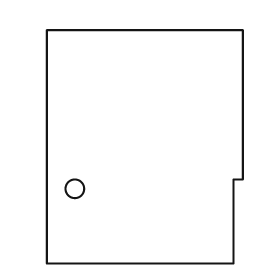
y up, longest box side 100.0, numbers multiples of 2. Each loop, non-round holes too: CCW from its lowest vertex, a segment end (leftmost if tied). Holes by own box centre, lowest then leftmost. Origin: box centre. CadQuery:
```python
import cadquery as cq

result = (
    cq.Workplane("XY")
    .moveTo(-42.0, -50.0)
    .lineTo(38.0, -50.0)
    .lineTo(38.0, -14.0)
    .lineTo(42.0, -14.0)
    .lineTo(42.0, 50.0)
    .lineTo(-42.0, 50.0)
    .close()
    .moveTo(-30.0, -18.0)
    .circle(4.0)
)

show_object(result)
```